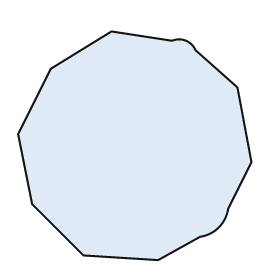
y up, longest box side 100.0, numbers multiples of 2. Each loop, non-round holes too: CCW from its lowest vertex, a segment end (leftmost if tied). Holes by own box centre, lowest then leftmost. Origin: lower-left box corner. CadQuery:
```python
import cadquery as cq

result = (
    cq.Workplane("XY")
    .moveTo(60.0, 0.0)
    .lineTo(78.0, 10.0)
    .threePointArc((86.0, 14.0), (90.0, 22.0))
    .lineTo(100.0, 42.0)
    .lineTo(94.0, 74.0)
    .lineTo(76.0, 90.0)
    .threePointArc((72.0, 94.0), (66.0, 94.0))
    .lineTo(40.0, 98.0)
    .lineTo(14.0, 82.0)
    .lineTo(0.0, 54.0)
    .lineTo(6.0, 24.0)
    .lineTo(28.0, 2.0)
    .close()
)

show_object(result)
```